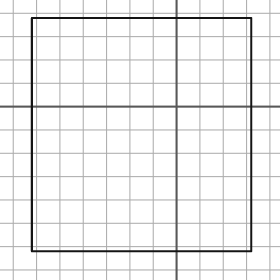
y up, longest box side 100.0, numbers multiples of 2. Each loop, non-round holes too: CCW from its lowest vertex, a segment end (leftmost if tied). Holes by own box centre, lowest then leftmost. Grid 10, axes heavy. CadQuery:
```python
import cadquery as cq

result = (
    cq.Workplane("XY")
    .moveTo(-62.0, -62.0)
    .lineTo(32.0, -62.0)
    .lineTo(32.0, 38.0)
    .lineTo(-62.0, 38.0)
    .close()
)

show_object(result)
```